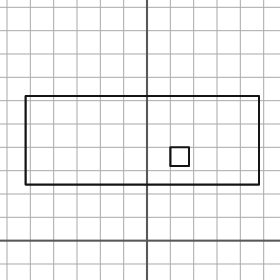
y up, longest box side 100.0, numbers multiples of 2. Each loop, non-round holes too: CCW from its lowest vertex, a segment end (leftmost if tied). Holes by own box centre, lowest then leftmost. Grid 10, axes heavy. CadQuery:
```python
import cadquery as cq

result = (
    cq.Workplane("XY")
    .moveTo(-52.0, 24.0)
    .lineTo(48.0, 24.0)
    .lineTo(48.0, 62.0)
    .lineTo(-52.0, 62.0)
    .close()
    .moveTo(10.0, 32.0)
    .lineTo(18.0, 32.0)
    .lineTo(18.0, 40.0)
    .lineTo(10.0, 40.0)
    .close()
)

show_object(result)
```